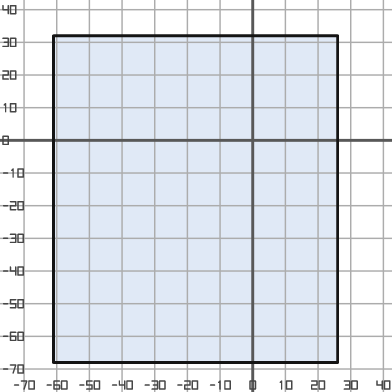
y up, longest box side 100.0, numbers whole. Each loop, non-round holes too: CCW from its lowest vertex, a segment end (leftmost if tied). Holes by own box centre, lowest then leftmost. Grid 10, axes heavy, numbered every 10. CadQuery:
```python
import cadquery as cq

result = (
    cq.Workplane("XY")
    .moveTo(-61.0, -68.0)
    .lineTo(26.0, -68.0)
    .lineTo(26.0, 32.0)
    .lineTo(-61.0, 32.0)
    .close()
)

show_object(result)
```